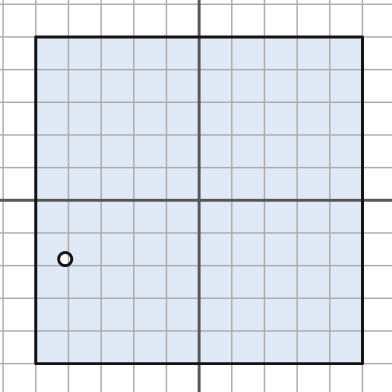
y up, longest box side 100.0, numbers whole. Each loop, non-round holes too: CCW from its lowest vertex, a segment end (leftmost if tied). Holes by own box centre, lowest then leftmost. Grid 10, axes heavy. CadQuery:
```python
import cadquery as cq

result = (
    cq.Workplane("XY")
    .moveTo(-50.0, -50.0)
    .lineTo(50.0, -50.0)
    .lineTo(50.0, 50.0)
    .lineTo(-50.0, 50.0)
    .close()
    .moveTo(-41.0, -18.0)
    .circle(2.0)
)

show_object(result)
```